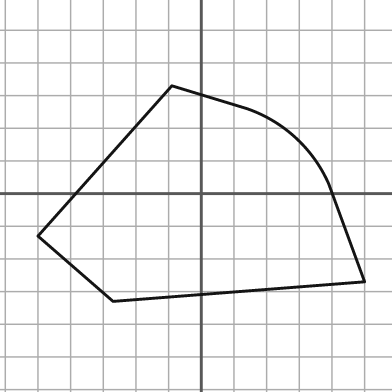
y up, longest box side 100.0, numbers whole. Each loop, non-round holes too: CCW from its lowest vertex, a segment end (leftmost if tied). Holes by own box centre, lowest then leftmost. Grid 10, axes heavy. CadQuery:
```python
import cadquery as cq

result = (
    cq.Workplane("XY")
    .moveTo(-27.0, -33.0)
    .lineTo(50.0, -27.0)
    .lineTo(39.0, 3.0)
    .threePointArc((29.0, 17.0), (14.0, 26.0))
    .lineTo(-9.0, 33.0)
    .lineTo(-50.0, -13.0)
    .close()
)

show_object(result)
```